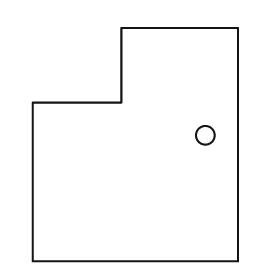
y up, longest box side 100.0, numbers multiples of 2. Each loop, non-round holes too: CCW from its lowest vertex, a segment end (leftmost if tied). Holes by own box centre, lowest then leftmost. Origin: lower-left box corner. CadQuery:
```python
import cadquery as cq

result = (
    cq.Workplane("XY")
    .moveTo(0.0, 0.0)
    .lineTo(88.0, 0.0)
    .lineTo(88.0, 100.0)
    .lineTo(38.0, 100.0)
    .lineTo(38.0, 68.0)
    .lineTo(0.0, 68.0)
    .close()
    .moveTo(74.0, 54.0)
    .circle(4.0)
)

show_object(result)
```